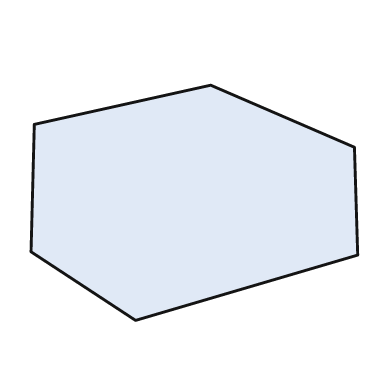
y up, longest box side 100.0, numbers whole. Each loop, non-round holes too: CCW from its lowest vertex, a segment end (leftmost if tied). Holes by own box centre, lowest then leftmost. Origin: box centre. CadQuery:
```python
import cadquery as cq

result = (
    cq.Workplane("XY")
    .moveTo(-18.0, -36.0)
    .lineTo(50.0, -16.0)
    .lineTo(49.0, 17.0)
    .lineTo(5.0, 36.0)
    .lineTo(-49.0, 24.0)
    .lineTo(-50.0, -15.0)
    .close()
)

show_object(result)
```